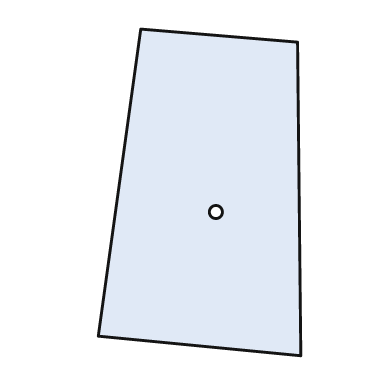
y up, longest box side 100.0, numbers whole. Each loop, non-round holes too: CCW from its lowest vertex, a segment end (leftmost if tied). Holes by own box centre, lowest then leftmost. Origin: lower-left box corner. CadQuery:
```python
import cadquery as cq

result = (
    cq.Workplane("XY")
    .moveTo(62.0, 0.0)
    .lineTo(61.0, 96.0)
    .lineTo(13.0, 100.0)
    .lineTo(0.0, 6.0)
    .close()
    .moveTo(36.0, 44.0)
    .circle(2.0)
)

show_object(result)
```